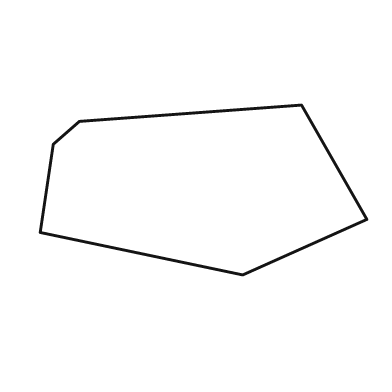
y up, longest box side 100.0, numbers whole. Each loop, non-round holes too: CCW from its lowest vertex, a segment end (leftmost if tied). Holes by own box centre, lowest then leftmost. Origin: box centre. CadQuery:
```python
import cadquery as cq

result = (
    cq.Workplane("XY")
    .moveTo(12.0, -26.0)
    .lineTo(50.0, -9.0)
    .lineTo(30.0, 26.0)
    .lineTo(-38.0, 21.0)
    .lineTo(-46.0, 14.0)
    .lineTo(-50.0, -13.0)
    .close()
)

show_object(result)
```